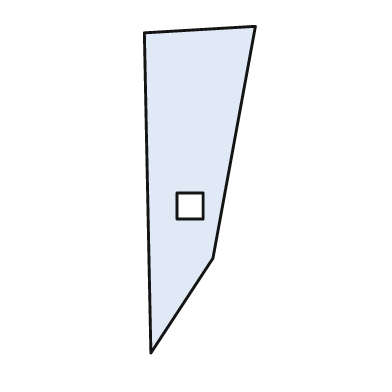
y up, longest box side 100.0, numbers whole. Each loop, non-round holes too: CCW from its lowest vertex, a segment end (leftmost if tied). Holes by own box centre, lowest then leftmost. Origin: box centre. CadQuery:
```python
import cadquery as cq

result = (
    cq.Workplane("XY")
    .moveTo(-15.0, -50.0)
    .lineTo(4.0, -21.0)
    .lineTo(17.0, 50.0)
    .lineTo(-17.0, 48.0)
    .close()
    .moveTo(-7.0, -9.0)
    .lineTo(1.0, -9.0)
    .lineTo(1.0, -1.0)
    .lineTo(-7.0, -1.0)
    .close()
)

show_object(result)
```